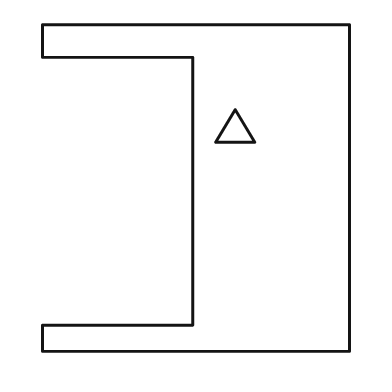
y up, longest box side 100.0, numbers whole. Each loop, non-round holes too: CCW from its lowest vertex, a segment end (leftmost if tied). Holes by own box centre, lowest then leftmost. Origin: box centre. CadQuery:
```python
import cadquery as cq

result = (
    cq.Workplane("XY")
    .moveTo(-47.0, -50.0)
    .lineTo(47.0, -50.0)
    .lineTo(47.0, 50.0)
    .lineTo(-47.0, 50.0)
    .lineTo(-47.0, 40.0)
    .lineTo(-1.0, 40.0)
    .lineTo(-1.0, -42.0)
    .lineTo(-47.0, -42.0)
    .close()
    .moveTo(6.0, 14.0)
    .lineTo(18.0, 14.0)
    .lineTo(12.0, 24.0)
    .close()
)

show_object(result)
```